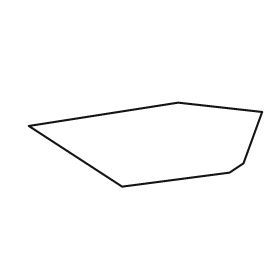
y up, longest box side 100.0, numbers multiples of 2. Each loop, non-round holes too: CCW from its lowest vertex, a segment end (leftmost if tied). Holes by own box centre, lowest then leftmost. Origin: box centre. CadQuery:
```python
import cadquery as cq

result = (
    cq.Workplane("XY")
    .moveTo(-10.0, -18.0)
    .lineTo(36.0, -12.0)
    .lineTo(42.0, -8.0)
    .lineTo(50.0, 14.0)
    .lineTo(14.0, 18.0)
    .lineTo(-50.0, 8.0)
    .close()
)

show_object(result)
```